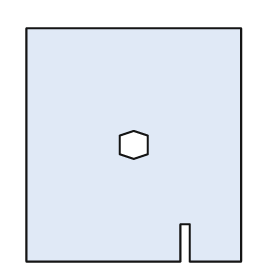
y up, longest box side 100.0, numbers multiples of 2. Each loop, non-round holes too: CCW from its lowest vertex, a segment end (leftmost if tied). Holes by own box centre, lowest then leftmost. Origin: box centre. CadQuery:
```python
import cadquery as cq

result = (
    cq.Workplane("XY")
    .moveTo(-46.0, -50.0)
    .lineTo(20.0, -50.0)
    .lineTo(20.0, -34.0)
    .lineTo(24.0, -34.0)
    .lineTo(24.0, -50.0)
    .lineTo(46.0, -50.0)
    .lineTo(46.0, 50.0)
    .lineTo(-46.0, 50.0)
    .close()
    .moveTo(0.0, -6.0)
    .lineTo(6.0, -4.0)
    .lineTo(6.0, 4.0)
    .lineTo(0.0, 6.0)
    .lineTo(-6.0, 4.0)
    .lineTo(-6.0, -4.0)
    .close()
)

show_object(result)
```